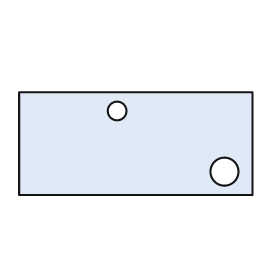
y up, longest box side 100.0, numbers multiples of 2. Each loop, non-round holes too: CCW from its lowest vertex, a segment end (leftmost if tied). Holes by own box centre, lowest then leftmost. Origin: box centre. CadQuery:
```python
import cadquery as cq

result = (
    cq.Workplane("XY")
    .moveTo(-50.0, -22.0)
    .lineTo(50.0, -22.0)
    .lineTo(50.0, 22.0)
    .lineTo(-50.0, 22.0)
    .close()
    .moveTo(38.0, -12.0)
    .circle(6.0)
    .moveTo(-8.0, 14.0)
    .circle(4.0)
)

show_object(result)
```